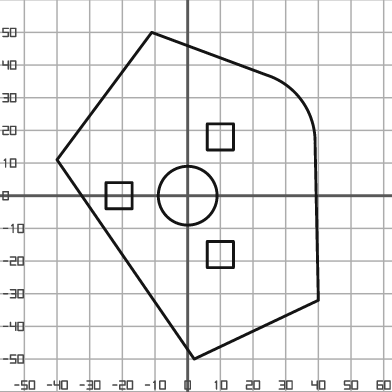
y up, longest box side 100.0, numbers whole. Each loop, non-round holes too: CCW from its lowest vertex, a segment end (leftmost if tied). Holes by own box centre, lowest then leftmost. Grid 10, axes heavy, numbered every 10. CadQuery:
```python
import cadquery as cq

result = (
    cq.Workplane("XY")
    .moveTo(2.0, -50.0)
    .lineTo(40.0, -32.0)
    .lineTo(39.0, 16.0)
    .threePointArc((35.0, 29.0), (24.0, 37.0))
    .lineTo(-11.0, 50.0)
    .lineTo(-40.0, 11.0)
    .close()
    .moveTo(6.0, -22.0)
    .lineTo(14.0, -22.0)
    .lineTo(14.0, -14.0)
    .lineTo(6.0, -14.0)
    .close()
    .moveTo(-25.0, -4.0)
    .lineTo(-17.0, -4.0)
    .lineTo(-17.0, 4.0)
    .lineTo(-25.0, 4.0)
    .close()
    .moveTo(0.0, 0.0)
    .circle(9.0)
    .moveTo(6.0, 14.0)
    .lineTo(14.0, 14.0)
    .lineTo(14.0, 22.0)
    .lineTo(6.0, 22.0)
    .close()
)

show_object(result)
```